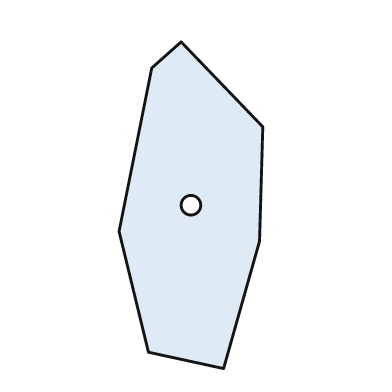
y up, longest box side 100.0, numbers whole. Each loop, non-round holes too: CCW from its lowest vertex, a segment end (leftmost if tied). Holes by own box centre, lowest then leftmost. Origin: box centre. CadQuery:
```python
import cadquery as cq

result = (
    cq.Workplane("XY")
    .moveTo(10.0, -50.0)
    .lineTo(21.0, -11.0)
    .lineTo(22.0, 24.0)
    .lineTo(-3.0, 50.0)
    .lineTo(-12.0, 42.0)
    .lineTo(-22.0, -8.0)
    .lineTo(-13.0, -45.0)
    .close()
    .moveTo(0.0, 0.0)
    .circle(3.0)
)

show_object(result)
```